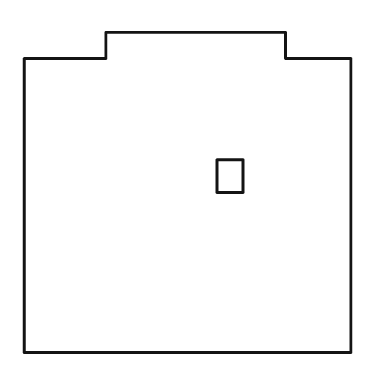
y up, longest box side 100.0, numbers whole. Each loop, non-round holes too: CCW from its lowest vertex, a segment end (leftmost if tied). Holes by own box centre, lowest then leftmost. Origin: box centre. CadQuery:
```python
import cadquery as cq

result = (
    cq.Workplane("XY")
    .moveTo(-50.0, -49.0)
    .lineTo(50.0, -49.0)
    .lineTo(50.0, 41.0)
    .lineTo(30.0, 41.0)
    .lineTo(30.0, 49.0)
    .lineTo(-25.0, 49.0)
    .lineTo(-25.0, 41.0)
    .lineTo(-50.0, 41.0)
    .close()
    .moveTo(9.0, 0.0)
    .lineTo(17.0, 0.0)
    .lineTo(17.0, 10.0)
    .lineTo(9.0, 10.0)
    .close()
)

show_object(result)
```